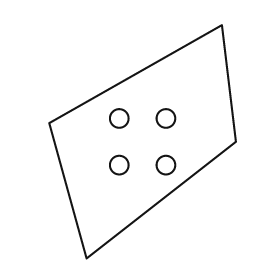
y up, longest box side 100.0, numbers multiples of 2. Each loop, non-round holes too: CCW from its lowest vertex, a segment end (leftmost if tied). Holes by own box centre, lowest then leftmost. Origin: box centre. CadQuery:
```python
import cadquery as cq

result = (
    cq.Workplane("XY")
    .moveTo(-24.0, -50.0)
    .lineTo(40.0, 0.0)
    .lineTo(34.0, 50.0)
    .lineTo(-40.0, 8.0)
    .close()
    .moveTo(-10.0, -10.0)
    .circle(4.0)
    .moveTo(10.0, -10.0)
    .circle(4.0)
    .moveTo(-10.0, 10.0)
    .circle(4.0)
    .moveTo(10.0, 10.0)
    .circle(4.0)
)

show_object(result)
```